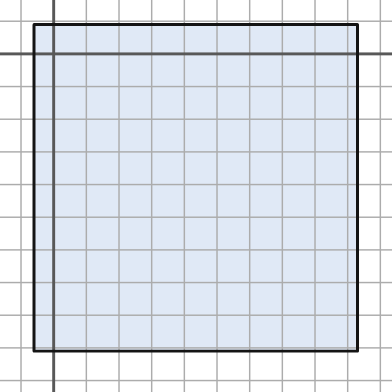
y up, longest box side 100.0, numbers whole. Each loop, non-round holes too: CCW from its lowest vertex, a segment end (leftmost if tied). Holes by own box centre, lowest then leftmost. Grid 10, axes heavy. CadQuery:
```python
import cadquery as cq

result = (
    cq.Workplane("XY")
    .moveTo(-6.0, -91.0)
    .lineTo(93.0, -91.0)
    .lineTo(93.0, 9.0)
    .lineTo(-6.0, 9.0)
    .close()
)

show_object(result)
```